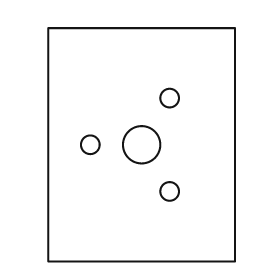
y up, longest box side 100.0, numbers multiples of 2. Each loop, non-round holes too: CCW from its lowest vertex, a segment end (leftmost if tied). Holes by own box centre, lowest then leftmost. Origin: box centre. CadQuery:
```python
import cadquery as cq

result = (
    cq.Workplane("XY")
    .moveTo(-40.0, -50.0)
    .lineTo(40.0, -50.0)
    .lineTo(40.0, 50.0)
    .lineTo(-40.0, 50.0)
    .close()
    .moveTo(12.0, -20.0)
    .circle(4.0)
    .moveTo(-22.0, 0.0)
    .circle(4.0)
    .moveTo(0.0, 0.0)
    .circle(8.0)
    .moveTo(12.0, 20.0)
    .circle(4.0)
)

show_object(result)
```